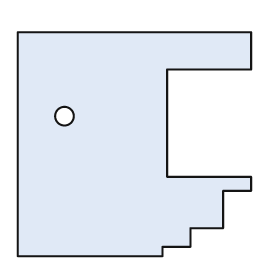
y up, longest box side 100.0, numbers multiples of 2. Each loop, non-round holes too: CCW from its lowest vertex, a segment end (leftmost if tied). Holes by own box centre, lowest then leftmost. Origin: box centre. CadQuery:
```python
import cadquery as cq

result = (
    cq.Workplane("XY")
    .moveTo(-50.0, -48.0)
    .lineTo(12.0, -48.0)
    .lineTo(12.0, -44.0)
    .lineTo(24.0, -44.0)
    .lineTo(24.0, -36.0)
    .lineTo(38.0, -36.0)
    .lineTo(38.0, -20.0)
    .lineTo(50.0, -20.0)
    .lineTo(50.0, -14.0)
    .lineTo(14.0, -14.0)
    .lineTo(14.0, 32.0)
    .lineTo(50.0, 32.0)
    .lineTo(50.0, 48.0)
    .lineTo(-50.0, 48.0)
    .close()
    .moveTo(-30.0, 12.0)
    .circle(4.0)
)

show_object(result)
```